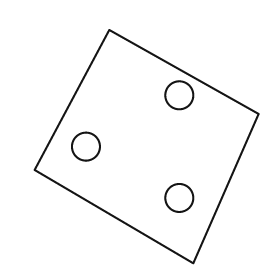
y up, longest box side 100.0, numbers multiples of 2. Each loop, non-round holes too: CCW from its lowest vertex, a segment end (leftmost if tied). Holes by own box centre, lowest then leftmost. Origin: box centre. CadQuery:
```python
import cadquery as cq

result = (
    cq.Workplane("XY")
    .moveTo(20.0, -50.0)
    .lineTo(48.0, 14.0)
    .lineTo(-16.0, 50.0)
    .lineTo(-48.0, -10.0)
    .close()
    .moveTo(14.0, -22.0)
    .circle(6.0)
    .moveTo(-26.0, 0.0)
    .circle(6.0)
    .moveTo(14.0, 22.0)
    .circle(6.0)
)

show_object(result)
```